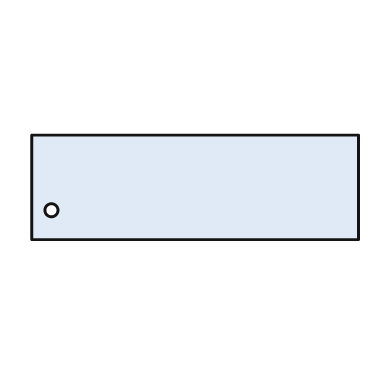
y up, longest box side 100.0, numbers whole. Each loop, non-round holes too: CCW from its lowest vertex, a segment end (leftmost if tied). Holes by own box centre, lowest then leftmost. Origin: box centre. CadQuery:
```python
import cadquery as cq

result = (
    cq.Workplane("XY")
    .moveTo(-50.0, -16.0)
    .lineTo(50.0, -16.0)
    .lineTo(50.0, 16.0)
    .lineTo(-50.0, 16.0)
    .close()
    .moveTo(-44.0, -7.0)
    .circle(2.0)
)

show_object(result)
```